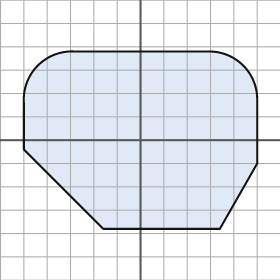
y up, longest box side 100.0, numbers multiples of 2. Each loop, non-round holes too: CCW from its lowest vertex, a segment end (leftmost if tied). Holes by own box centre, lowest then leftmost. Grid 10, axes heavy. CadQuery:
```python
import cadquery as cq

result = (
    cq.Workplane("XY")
    .moveTo(-16.0, -38.0)
    .lineTo(34.0, -38.0)
    .lineTo(50.0, -10.0)
    .lineTo(50.0, 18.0)
    .threePointArc((44.0, 32.0), (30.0, 38.0))
    .lineTo(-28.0, 38.0)
    .threePointArc((-44.0, 32.0), (-50.0, 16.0))
    .lineTo(-50.0, -4.0)
    .close()
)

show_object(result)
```